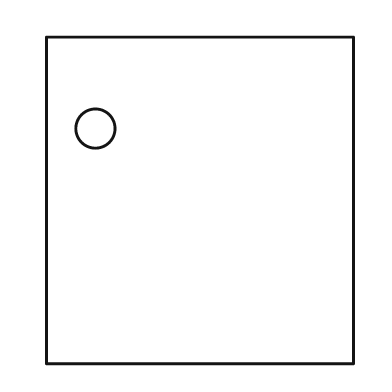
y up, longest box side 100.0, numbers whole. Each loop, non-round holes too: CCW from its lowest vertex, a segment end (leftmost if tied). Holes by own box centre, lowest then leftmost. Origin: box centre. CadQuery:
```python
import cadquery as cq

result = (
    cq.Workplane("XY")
    .moveTo(-47.0, -50.0)
    .lineTo(47.0, -50.0)
    .lineTo(47.0, 50.0)
    .lineTo(-47.0, 50.0)
    .close()
    .moveTo(-32.0, 22.0)
    .circle(6.0)
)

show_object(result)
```